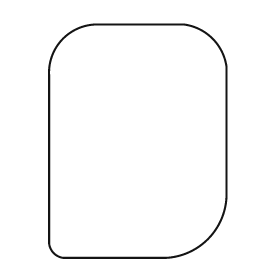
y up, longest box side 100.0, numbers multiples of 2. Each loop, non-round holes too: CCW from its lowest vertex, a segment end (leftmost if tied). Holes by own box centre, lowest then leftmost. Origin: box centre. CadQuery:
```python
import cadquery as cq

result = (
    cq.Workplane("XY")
    .moveTo(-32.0, -50.0)
    .lineTo(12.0, -50.0)
    .threePointArc((30.0, -42.0), (38.0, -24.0))
    .lineTo(38.0, 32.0)
    .threePointArc((32.0, 44.0), (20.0, 50.0))
    .lineTo(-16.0, 50.0)
    .threePointArc((-32.0, 44.0), (-38.0, 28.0))
    .lineTo(-38.0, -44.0)
    .threePointArc((-36.0, -48.0), (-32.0, -50.0))
    .close()
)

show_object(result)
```